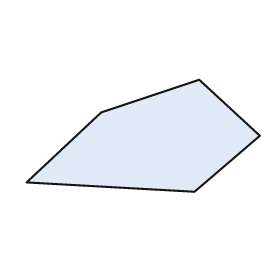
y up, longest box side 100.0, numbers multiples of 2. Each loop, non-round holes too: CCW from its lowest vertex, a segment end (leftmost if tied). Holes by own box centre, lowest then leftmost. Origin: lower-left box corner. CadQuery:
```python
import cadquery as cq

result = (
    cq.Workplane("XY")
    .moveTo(72.0, 0.0)
    .lineTo(100.0, 24.0)
    .lineTo(74.0, 48.0)
    .lineTo(32.0, 34.0)
    .lineTo(0.0, 4.0)
    .close()
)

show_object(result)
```